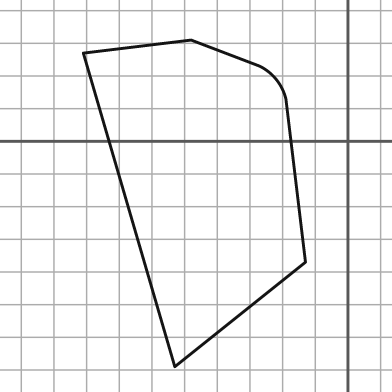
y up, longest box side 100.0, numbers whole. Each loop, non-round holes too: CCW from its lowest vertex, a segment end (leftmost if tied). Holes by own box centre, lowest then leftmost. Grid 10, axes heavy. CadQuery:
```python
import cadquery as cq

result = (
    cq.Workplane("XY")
    .moveTo(-53.0, -69.0)
    .lineTo(-13.0, -37.0)
    .lineTo(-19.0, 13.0)
    .threePointArc((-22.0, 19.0), (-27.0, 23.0))
    .lineTo(-48.0, 31.0)
    .lineTo(-81.0, 27.0)
    .close()
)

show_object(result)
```